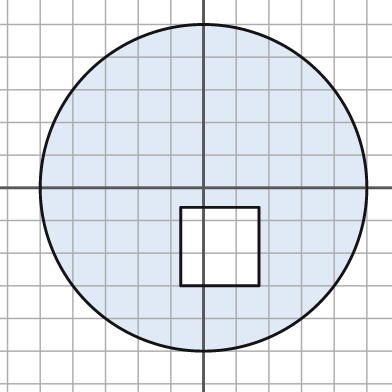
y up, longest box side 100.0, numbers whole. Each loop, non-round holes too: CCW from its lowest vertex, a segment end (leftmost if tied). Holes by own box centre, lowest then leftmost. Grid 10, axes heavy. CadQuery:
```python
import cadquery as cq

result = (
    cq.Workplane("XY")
    .moveTo(0.0, 0.0)
    .circle(50.0)
    .moveTo(-7.0, -30.0)
    .lineTo(17.0, -30.0)
    .lineTo(17.0, -6.0)
    .lineTo(-7.0, -6.0)
    .close()
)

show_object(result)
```